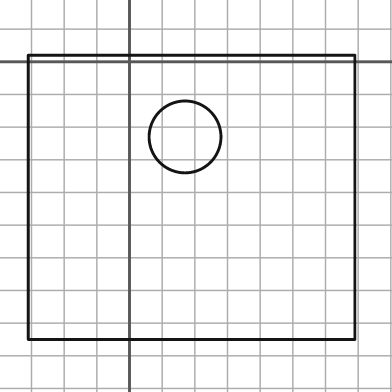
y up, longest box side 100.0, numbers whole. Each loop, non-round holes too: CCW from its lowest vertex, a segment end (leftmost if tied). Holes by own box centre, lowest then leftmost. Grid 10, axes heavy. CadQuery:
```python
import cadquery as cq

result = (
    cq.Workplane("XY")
    .moveTo(-31.0, -85.0)
    .lineTo(69.0, -85.0)
    .lineTo(69.0, 2.0)
    .lineTo(-31.0, 2.0)
    .close()
    .moveTo(17.0, -23.0)
    .circle(11.0)
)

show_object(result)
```